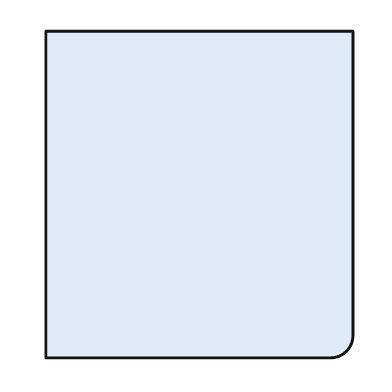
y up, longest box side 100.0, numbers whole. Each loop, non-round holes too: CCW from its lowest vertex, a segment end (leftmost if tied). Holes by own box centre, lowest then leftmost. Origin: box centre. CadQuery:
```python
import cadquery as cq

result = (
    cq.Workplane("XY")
    .moveTo(-47.0, -50.0)
    .lineTo(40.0, -50.0)
    .threePointArc((45.0, -48.0), (47.0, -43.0))
    .lineTo(47.0, 50.0)
    .lineTo(-47.0, 50.0)
    .close()
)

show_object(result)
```